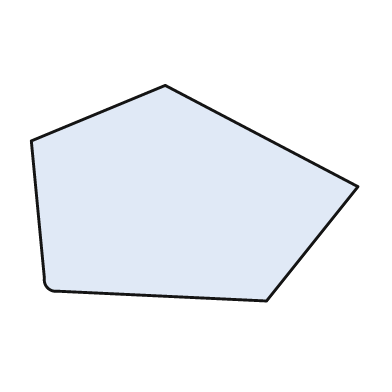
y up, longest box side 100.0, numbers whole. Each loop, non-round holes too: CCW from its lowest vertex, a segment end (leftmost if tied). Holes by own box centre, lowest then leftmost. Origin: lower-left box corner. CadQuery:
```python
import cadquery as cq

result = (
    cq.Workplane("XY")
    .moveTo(72.0, 0.0)
    .lineTo(100.0, 35.0)
    .lineTo(41.0, 66.0)
    .lineTo(0.0, 49.0)
    .lineTo(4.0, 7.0)
    .threePointArc((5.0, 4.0), (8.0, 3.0))
    .close()
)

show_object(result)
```